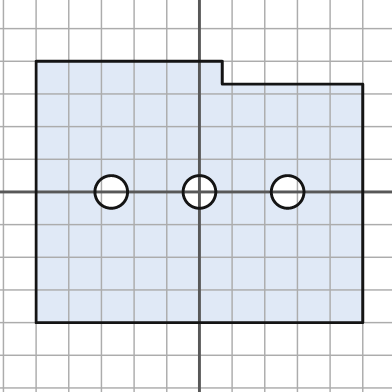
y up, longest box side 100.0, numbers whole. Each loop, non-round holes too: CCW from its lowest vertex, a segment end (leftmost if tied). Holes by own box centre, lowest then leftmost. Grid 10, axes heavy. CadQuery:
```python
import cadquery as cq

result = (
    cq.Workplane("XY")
    .moveTo(-50.0, -40.0)
    .lineTo(50.0, -40.0)
    .lineTo(50.0, 33.0)
    .lineTo(7.0, 33.0)
    .lineTo(7.0, 40.0)
    .lineTo(-50.0, 40.0)
    .close()
    .moveTo(-27.0, 0.0)
    .circle(5.0)
    .moveTo(0.0, 0.0)
    .circle(5.0)
    .moveTo(27.0, 0.0)
    .circle(5.0)
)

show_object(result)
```